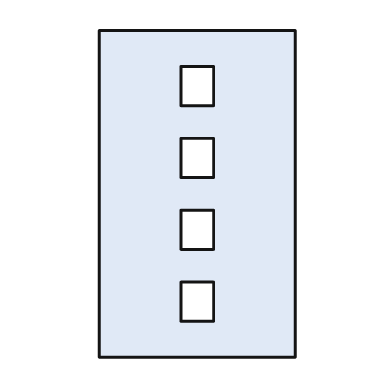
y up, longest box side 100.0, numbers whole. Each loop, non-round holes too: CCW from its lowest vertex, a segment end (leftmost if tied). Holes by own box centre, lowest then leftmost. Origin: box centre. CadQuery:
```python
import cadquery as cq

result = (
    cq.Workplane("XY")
    .moveTo(-30.0, -50.0)
    .lineTo(30.0, -50.0)
    .lineTo(30.0, 50.0)
    .lineTo(-30.0, 50.0)
    .close()
    .moveTo(-5.0, -39.0)
    .lineTo(5.0, -39.0)
    .lineTo(5.0, -27.0)
    .lineTo(-5.0, -27.0)
    .close()
    .moveTo(-5.0, -17.0)
    .lineTo(5.0, -17.0)
    .lineTo(5.0, -5.0)
    .lineTo(-5.0, -5.0)
    .close()
    .moveTo(-5.0, 5.0)
    .lineTo(5.0, 5.0)
    .lineTo(5.0, 17.0)
    .lineTo(-5.0, 17.0)
    .close()
    .moveTo(-5.0, 27.0)
    .lineTo(5.0, 27.0)
    .lineTo(5.0, 39.0)
    .lineTo(-5.0, 39.0)
    .close()
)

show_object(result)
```